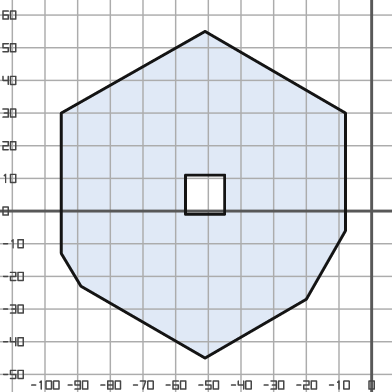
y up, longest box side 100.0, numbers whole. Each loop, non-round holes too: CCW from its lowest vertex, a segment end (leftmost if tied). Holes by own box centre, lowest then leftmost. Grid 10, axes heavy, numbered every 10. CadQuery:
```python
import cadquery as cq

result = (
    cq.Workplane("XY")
    .moveTo(-51.0, -45.0)
    .lineTo(-20.0, -27.0)
    .lineTo(-8.0, -6.0)
    .lineTo(-8.0, 30.0)
    .lineTo(-51.0, 55.0)
    .lineTo(-95.0, 30.0)
    .lineTo(-95.0, -13.0)
    .lineTo(-89.0, -23.0)
    .close()
    .moveTo(-57.0, -1.0)
    .lineTo(-45.0, -1.0)
    .lineTo(-45.0, 11.0)
    .lineTo(-57.0, 11.0)
    .close()
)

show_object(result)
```